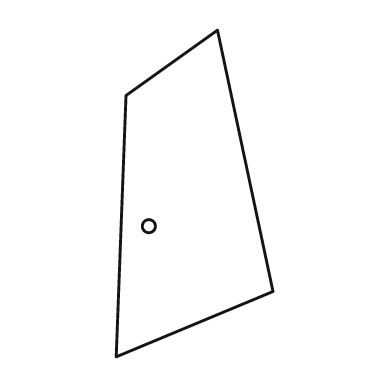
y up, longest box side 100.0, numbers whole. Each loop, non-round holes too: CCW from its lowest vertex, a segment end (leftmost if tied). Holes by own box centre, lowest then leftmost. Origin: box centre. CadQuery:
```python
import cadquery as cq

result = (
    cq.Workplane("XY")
    .moveTo(-24.0, -50.0)
    .lineTo(24.0, -30.0)
    .lineTo(7.0, 50.0)
    .lineTo(-21.0, 30.0)
    .close()
    .moveTo(-14.0, -10.0)
    .circle(2.0)
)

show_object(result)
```